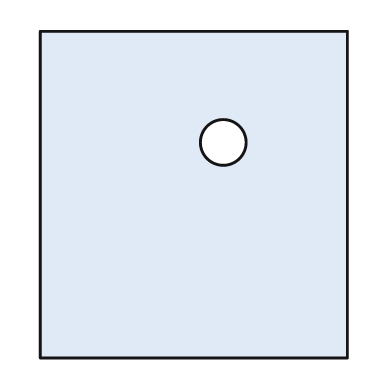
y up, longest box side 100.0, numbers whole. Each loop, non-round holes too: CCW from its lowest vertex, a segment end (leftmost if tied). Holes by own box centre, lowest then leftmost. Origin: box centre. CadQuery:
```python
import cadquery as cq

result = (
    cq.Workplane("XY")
    .moveTo(-47.0, -50.0)
    .lineTo(47.0, -50.0)
    .lineTo(47.0, 50.0)
    .lineTo(-47.0, 50.0)
    .close()
    .moveTo(9.0, 16.0)
    .circle(7.0)
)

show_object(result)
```